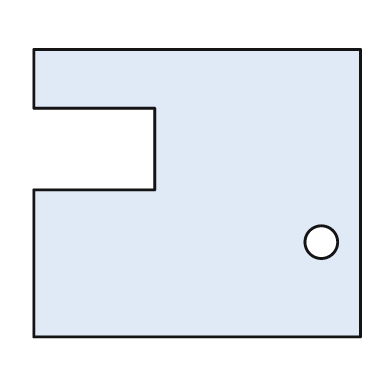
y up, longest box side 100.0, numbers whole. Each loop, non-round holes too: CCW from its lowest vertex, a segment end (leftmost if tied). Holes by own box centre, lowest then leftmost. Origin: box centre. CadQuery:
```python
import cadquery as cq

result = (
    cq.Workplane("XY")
    .moveTo(-50.0, -44.0)
    .lineTo(50.0, -44.0)
    .lineTo(50.0, 44.0)
    .lineTo(-50.0, 44.0)
    .lineTo(-50.0, 26.0)
    .lineTo(-13.0, 26.0)
    .lineTo(-13.0, 1.0)
    .lineTo(-50.0, 1.0)
    .close()
    .moveTo(38.0, -15.0)
    .circle(5.0)
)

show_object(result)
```